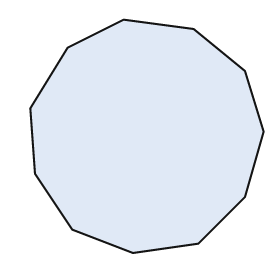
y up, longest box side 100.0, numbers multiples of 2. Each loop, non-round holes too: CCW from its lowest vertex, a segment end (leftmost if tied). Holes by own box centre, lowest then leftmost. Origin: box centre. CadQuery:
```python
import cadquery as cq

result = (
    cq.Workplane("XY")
    .moveTo(-6.0, -50.0)
    .lineTo(22.0, -46.0)
    .lineTo(42.0, -26.0)
    .lineTo(50.0, 2.0)
    .lineTo(42.0, 28.0)
    .lineTo(20.0, 46.0)
    .lineTo(-10.0, 50.0)
    .lineTo(-34.0, 38.0)
    .lineTo(-50.0, 12.0)
    .lineTo(-48.0, -16.0)
    .lineTo(-32.0, -40.0)
    .close()
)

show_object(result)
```